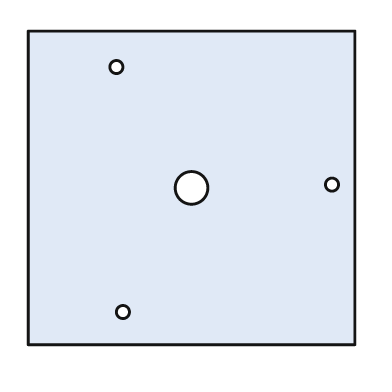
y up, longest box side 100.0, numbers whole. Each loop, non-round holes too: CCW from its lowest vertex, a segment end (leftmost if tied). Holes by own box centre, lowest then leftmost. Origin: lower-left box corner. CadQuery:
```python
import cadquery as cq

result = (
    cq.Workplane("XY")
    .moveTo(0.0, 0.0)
    .lineTo(100.0, 0.0)
    .lineTo(100.0, 96.0)
    .lineTo(0.0, 96.0)
    .close()
    .moveTo(29.0, 10.0)
    .circle(2.0)
    .moveTo(50.0, 48.0)
    .circle(5.0)
    .moveTo(93.0, 49.0)
    .circle(2.0)
    .moveTo(27.0, 85.0)
    .circle(2.0)
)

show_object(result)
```